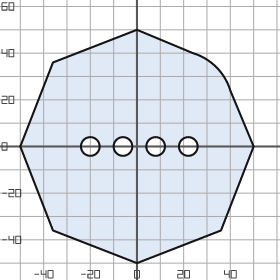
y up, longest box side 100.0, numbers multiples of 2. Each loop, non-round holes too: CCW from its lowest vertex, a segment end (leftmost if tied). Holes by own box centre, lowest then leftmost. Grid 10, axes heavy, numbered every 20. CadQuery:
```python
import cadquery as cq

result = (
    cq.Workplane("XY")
    .moveTo(0.0, -50.0)
    .lineTo(36.0, -36.0)
    .lineTo(50.0, 0.0)
    .lineTo(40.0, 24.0)
    .threePointArc((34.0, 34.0), (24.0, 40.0))
    .lineTo(0.0, 50.0)
    .lineTo(-36.0, 36.0)
    .lineTo(-50.0, 0.0)
    .lineTo(-36.0, -36.0)
    .close()
    .moveTo(-20.0, 0.0)
    .circle(4.0)
    .moveTo(-6.0, 0.0)
    .circle(4.0)
    .moveTo(8.0, 0.0)
    .circle(4.0)
    .moveTo(22.0, 0.0)
    .circle(4.0)
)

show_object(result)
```